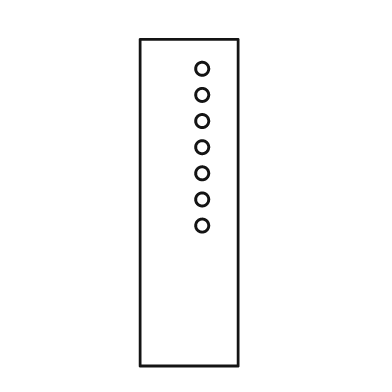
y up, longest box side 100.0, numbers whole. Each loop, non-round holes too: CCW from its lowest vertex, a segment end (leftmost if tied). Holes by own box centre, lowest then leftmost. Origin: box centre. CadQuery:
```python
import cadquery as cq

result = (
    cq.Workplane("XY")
    .moveTo(-15.0, -50.0)
    .lineTo(15.0, -50.0)
    .lineTo(15.0, 50.0)
    .lineTo(-15.0, 50.0)
    .close()
    .moveTo(4.0, -7.0)
    .circle(2.0)
    .moveTo(4.0, 1.0)
    .circle(2.0)
    .moveTo(4.0, 9.0)
    .circle(2.0)
    .moveTo(4.0, 17.0)
    .circle(2.0)
    .moveTo(4.0, 25.0)
    .circle(2.0)
    .moveTo(4.0, 33.0)
    .circle(2.0)
    .moveTo(4.0, 41.0)
    .circle(2.0)
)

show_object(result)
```